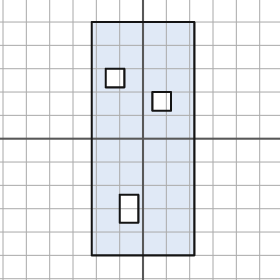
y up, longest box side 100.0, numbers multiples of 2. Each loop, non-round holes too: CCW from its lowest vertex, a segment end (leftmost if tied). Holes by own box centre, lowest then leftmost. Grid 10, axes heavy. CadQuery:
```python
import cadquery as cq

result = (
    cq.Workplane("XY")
    .moveTo(-22.0, -50.0)
    .lineTo(22.0, -50.0)
    .lineTo(22.0, 50.0)
    .lineTo(-22.0, 50.0)
    .close()
    .moveTo(-10.0, -36.0)
    .lineTo(-2.0, -36.0)
    .lineTo(-2.0, -24.0)
    .lineTo(-10.0, -24.0)
    .close()
    .moveTo(4.0, 12.0)
    .lineTo(12.0, 12.0)
    .lineTo(12.0, 20.0)
    .lineTo(4.0, 20.0)
    .close()
    .moveTo(-16.0, 22.0)
    .lineTo(-8.0, 22.0)
    .lineTo(-8.0, 30.0)
    .lineTo(-16.0, 30.0)
    .close()
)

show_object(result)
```